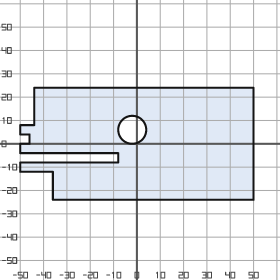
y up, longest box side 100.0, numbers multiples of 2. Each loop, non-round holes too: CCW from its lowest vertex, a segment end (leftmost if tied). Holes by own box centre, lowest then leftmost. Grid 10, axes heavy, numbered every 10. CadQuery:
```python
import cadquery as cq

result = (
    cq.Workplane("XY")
    .moveTo(-36.0, -24.0)
    .lineTo(50.0, -24.0)
    .lineTo(50.0, 24.0)
    .lineTo(-44.0, 24.0)
    .lineTo(-44.0, 8.0)
    .lineTo(-50.0, 8.0)
    .lineTo(-50.0, 4.0)
    .lineTo(-46.0, 4.0)
    .lineTo(-46.0, 0.0)
    .lineTo(-50.0, 0.0)
    .lineTo(-50.0, -4.0)
    .lineTo(-8.0, -4.0)
    .lineTo(-8.0, -8.0)
    .lineTo(-50.0, -8.0)
    .lineTo(-50.0, -12.0)
    .lineTo(-36.0, -12.0)
    .close()
    .moveTo(-2.0, 6.0)
    .circle(6.0)
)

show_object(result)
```